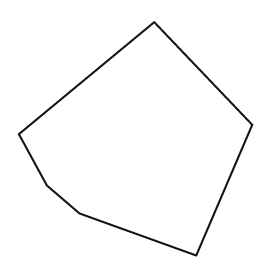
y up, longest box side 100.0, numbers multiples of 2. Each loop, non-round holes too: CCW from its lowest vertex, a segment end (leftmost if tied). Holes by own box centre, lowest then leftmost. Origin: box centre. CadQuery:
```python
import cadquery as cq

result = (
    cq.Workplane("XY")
    .moveTo(26.0, -50.0)
    .lineTo(50.0, 6.0)
    .lineTo(8.0, 50.0)
    .lineTo(-50.0, 2.0)
    .lineTo(-38.0, -20.0)
    .lineTo(-24.0, -32.0)
    .close()
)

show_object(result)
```